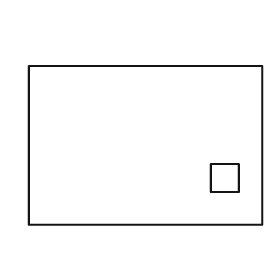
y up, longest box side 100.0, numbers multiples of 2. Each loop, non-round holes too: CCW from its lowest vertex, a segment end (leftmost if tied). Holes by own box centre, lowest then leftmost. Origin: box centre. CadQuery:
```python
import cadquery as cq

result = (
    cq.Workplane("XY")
    .moveTo(-50.0, -34.0)
    .lineTo(50.0, -34.0)
    .lineTo(50.0, 34.0)
    .lineTo(-50.0, 34.0)
    .close()
    .moveTo(28.0, -20.0)
    .lineTo(40.0, -20.0)
    .lineTo(40.0, -8.0)
    .lineTo(28.0, -8.0)
    .close()
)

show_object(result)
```